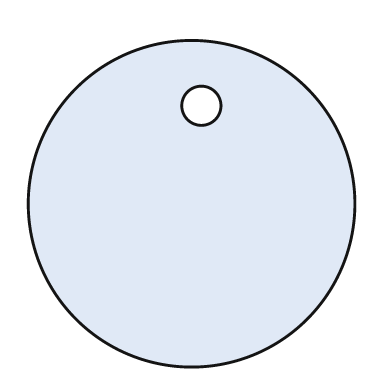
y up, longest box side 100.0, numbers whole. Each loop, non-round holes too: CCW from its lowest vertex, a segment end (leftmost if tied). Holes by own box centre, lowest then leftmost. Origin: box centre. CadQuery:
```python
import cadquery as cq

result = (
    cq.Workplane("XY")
    .moveTo(0.0, 0.0)
    .circle(50.0)
    .moveTo(3.0, 30.0)
    .circle(6.0)
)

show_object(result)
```